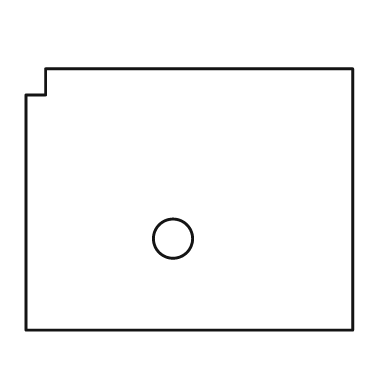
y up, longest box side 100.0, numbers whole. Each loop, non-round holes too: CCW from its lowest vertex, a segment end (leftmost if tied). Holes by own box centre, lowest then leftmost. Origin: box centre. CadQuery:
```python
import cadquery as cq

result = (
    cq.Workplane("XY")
    .moveTo(-50.0, -40.0)
    .lineTo(50.0, -40.0)
    .lineTo(50.0, 40.0)
    .lineTo(-44.0, 40.0)
    .lineTo(-44.0, 32.0)
    .lineTo(-50.0, 32.0)
    .close()
    .moveTo(-5.0, -12.0)
    .circle(6.0)
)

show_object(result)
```